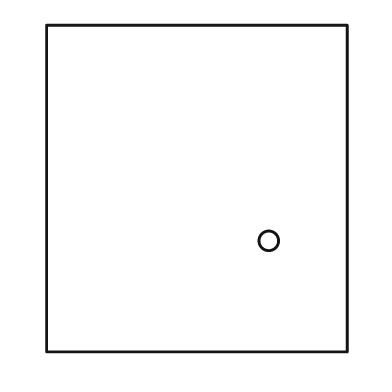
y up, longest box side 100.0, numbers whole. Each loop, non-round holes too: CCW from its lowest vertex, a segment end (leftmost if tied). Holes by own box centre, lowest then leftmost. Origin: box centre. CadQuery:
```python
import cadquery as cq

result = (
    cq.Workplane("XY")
    .moveTo(-46.0, -50.0)
    .lineTo(46.0, -50.0)
    .lineTo(46.0, 50.0)
    .lineTo(-46.0, 50.0)
    .close()
    .moveTo(22.0, -16.0)
    .circle(3.0)
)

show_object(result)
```